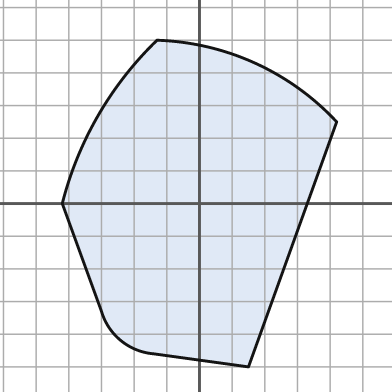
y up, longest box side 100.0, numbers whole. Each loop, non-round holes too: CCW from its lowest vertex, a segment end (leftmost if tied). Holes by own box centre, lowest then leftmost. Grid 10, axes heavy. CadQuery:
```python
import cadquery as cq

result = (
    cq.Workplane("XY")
    .moveTo(15.0, -50.0)
    .lineTo(42.0, 25.0)
    .threePointArc((17.0, 43.0), (-13.0, 50.0))
    .threePointArc((-31.0, 27.0), (-42.0, 0.0))
    .lineTo(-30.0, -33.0)
    .threePointArc((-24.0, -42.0), (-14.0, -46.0))
    .close()
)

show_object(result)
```